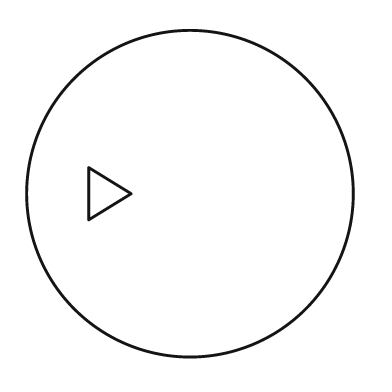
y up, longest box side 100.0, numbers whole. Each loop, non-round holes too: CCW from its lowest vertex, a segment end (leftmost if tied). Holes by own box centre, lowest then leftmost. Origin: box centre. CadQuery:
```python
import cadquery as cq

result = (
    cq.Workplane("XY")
    .moveTo(0.0, 0.0)
    .circle(50.0)
    .moveTo(-31.0, -8.0)
    .lineTo(-18.0, 0.0)
    .lineTo(-31.0, 8.0)
    .close()
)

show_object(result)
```